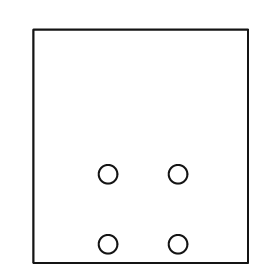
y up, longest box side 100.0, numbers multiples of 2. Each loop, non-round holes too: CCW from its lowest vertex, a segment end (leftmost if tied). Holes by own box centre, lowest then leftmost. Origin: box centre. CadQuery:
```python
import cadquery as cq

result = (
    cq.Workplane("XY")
    .moveTo(-46.0, -50.0)
    .lineTo(46.0, -50.0)
    .lineTo(46.0, 50.0)
    .lineTo(-46.0, 50.0)
    .close()
    .moveTo(-14.0, -42.0)
    .circle(4.0)
    .moveTo(16.0, -42.0)
    .circle(4.0)
    .moveTo(-14.0, -12.0)
    .circle(4.0)
    .moveTo(16.0, -12.0)
    .circle(4.0)
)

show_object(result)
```